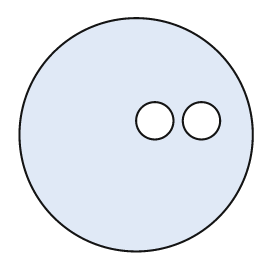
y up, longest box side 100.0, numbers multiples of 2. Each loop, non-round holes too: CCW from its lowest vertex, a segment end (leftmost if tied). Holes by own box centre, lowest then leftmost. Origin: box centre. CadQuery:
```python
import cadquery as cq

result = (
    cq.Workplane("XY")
    .moveTo(0.0, 0.0)
    .circle(50.0)
    .moveTo(8.0, 6.0)
    .circle(8.0)
    .moveTo(28.0, 6.0)
    .circle(8.0)
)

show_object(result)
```